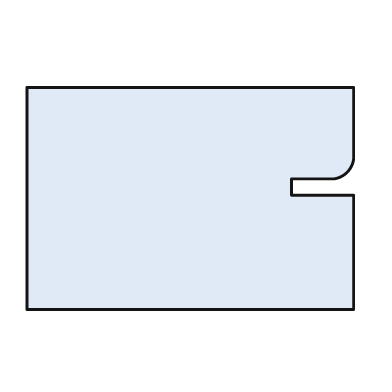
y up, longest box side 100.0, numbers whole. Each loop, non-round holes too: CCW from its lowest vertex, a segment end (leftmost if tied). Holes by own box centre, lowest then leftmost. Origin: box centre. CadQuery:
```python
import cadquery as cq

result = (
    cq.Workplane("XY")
    .moveTo(-50.0, -34.0)
    .lineTo(50.0, -34.0)
    .lineTo(50.0, 1.0)
    .lineTo(31.0, 1.0)
    .lineTo(31.0, 6.0)
    .lineTo(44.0, 6.0)
    .threePointArc((48.0, 8.0), (50.0, 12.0))
    .lineTo(50.0, 34.0)
    .lineTo(-50.0, 34.0)
    .close()
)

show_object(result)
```